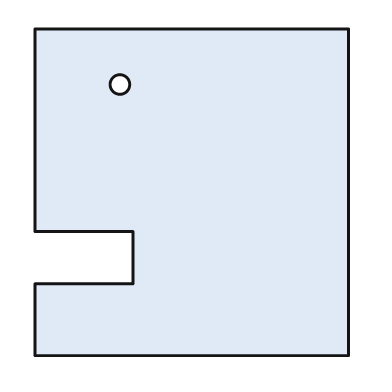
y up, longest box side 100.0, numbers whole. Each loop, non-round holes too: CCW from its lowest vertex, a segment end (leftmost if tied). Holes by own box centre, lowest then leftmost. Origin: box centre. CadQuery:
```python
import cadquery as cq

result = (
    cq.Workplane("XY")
    .moveTo(-48.0, -50.0)
    .lineTo(48.0, -50.0)
    .lineTo(48.0, 50.0)
    .lineTo(-48.0, 50.0)
    .lineTo(-48.0, -12.0)
    .lineTo(-18.0, -12.0)
    .lineTo(-18.0, -28.0)
    .lineTo(-48.0, -28.0)
    .close()
    .moveTo(-22.0, 33.0)
    .circle(3.0)
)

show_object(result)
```